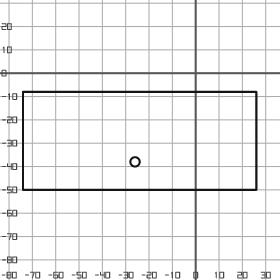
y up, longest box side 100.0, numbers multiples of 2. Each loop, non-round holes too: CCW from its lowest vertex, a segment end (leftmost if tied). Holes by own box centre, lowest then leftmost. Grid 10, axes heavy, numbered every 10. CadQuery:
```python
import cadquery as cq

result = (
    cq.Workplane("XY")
    .moveTo(-74.0, -50.0)
    .lineTo(26.0, -50.0)
    .lineTo(26.0, -8.0)
    .lineTo(-74.0, -8.0)
    .close()
    .moveTo(-26.0, -38.0)
    .circle(2.0)
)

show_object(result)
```